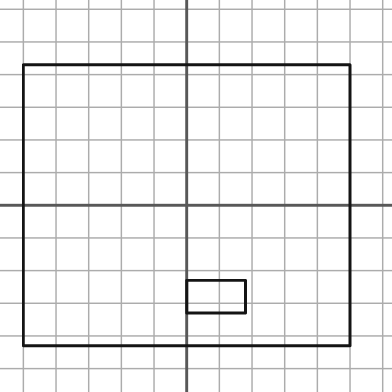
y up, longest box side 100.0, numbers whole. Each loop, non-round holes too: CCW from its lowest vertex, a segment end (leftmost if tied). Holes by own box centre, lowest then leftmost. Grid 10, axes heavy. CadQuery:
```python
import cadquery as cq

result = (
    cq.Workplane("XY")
    .moveTo(-50.0, -43.0)
    .lineTo(50.0, -43.0)
    .lineTo(50.0, 43.0)
    .lineTo(-50.0, 43.0)
    .close()
    .moveTo(0.0, -33.0)
    .lineTo(18.0, -33.0)
    .lineTo(18.0, -23.0)
    .lineTo(0.0, -23.0)
    .close()
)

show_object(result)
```